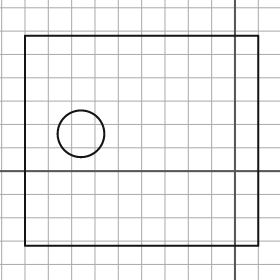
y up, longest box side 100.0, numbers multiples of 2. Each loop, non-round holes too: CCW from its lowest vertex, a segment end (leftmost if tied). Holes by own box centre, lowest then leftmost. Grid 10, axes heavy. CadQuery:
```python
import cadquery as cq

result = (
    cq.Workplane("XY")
    .moveTo(-90.0, -32.0)
    .lineTo(10.0, -32.0)
    .lineTo(10.0, 58.0)
    .lineTo(-90.0, 58.0)
    .close()
    .moveTo(-66.0, 16.0)
    .circle(10.0)
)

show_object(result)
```